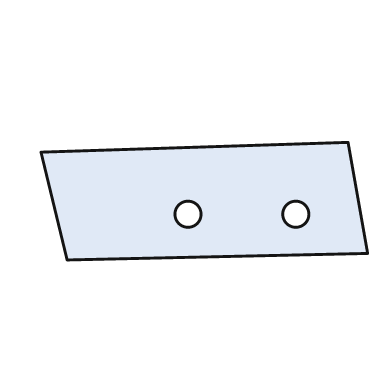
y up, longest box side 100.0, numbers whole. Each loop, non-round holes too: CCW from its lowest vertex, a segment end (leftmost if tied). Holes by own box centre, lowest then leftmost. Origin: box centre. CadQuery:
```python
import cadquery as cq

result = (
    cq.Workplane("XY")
    .moveTo(-42.0, -18.0)
    .lineTo(50.0, -16.0)
    .lineTo(44.0, 18.0)
    .lineTo(-50.0, 15.0)
    .close()
    .moveTo(-5.0, -4.0)
    .circle(4.0)
    .moveTo(28.0, -4.0)
    .circle(4.0)
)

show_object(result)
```